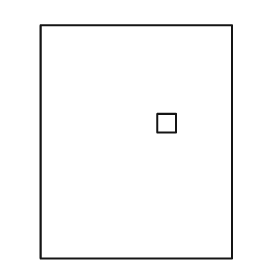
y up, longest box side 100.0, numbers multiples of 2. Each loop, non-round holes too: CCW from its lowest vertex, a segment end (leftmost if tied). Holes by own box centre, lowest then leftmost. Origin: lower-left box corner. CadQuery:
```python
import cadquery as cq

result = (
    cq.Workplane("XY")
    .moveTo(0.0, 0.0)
    .lineTo(82.0, 0.0)
    .lineTo(82.0, 100.0)
    .lineTo(0.0, 100.0)
    .close()
    .moveTo(50.0, 54.0)
    .lineTo(58.0, 54.0)
    .lineTo(58.0, 62.0)
    .lineTo(50.0, 62.0)
    .close()
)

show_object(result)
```